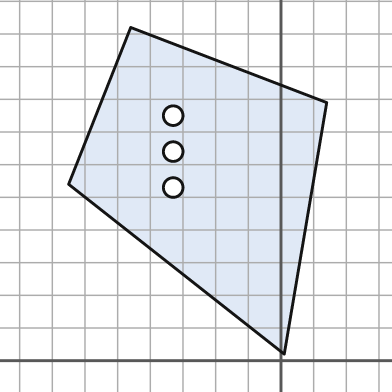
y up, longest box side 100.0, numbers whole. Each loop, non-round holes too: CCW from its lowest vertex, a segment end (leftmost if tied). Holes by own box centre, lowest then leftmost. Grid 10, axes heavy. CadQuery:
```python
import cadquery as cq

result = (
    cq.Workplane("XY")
    .moveTo(1.0, 2.0)
    .lineTo(14.0, 79.0)
    .lineTo(-46.0, 102.0)
    .lineTo(-65.0, 54.0)
    .close()
    .moveTo(-33.0, 53.0)
    .circle(3.0)
    .moveTo(-33.0, 64.0)
    .circle(3.0)
    .moveTo(-33.0, 75.0)
    .circle(3.0)
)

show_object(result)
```